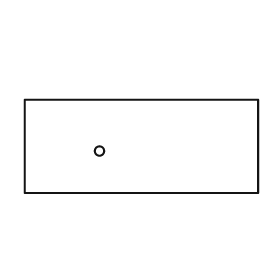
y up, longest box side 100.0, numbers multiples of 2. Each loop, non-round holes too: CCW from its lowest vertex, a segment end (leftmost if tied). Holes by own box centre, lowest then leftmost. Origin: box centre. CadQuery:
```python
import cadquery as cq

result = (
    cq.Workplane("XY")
    .moveTo(-50.0, -20.0)
    .lineTo(50.0, -20.0)
    .lineTo(50.0, 20.0)
    .lineTo(-50.0, 20.0)
    .close()
    .moveTo(-18.0, -2.0)
    .circle(2.0)
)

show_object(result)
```